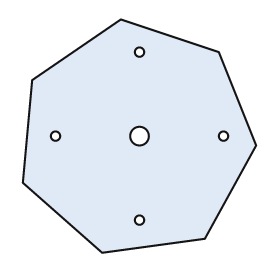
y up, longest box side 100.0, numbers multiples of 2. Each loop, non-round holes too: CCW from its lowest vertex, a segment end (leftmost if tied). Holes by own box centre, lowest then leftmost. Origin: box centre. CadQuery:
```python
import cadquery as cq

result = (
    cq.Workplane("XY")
    .moveTo(-16.0, -50.0)
    .lineTo(28.0, -44.0)
    .lineTo(50.0, -4.0)
    .lineTo(34.0, 36.0)
    .lineTo(-8.0, 50.0)
    .lineTo(-46.0, 24.0)
    .lineTo(-50.0, -20.0)
    .close()
    .moveTo(0.0, -36.0)
    .circle(2.0)
    .moveTo(-36.0, 0.0)
    .circle(2.0)
    .moveTo(0.0, 0.0)
    .circle(4.0)
    .moveTo(36.0, 0.0)
    .circle(2.0)
    .moveTo(0.0, 36.0)
    .circle(2.0)
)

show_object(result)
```